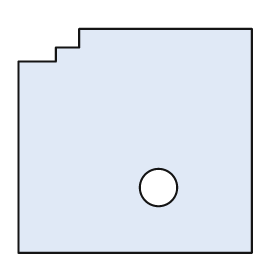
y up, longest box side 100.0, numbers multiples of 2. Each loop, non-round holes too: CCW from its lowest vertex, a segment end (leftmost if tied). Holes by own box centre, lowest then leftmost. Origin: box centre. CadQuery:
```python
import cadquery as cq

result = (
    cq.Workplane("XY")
    .moveTo(-50.0, -48.0)
    .lineTo(50.0, -48.0)
    .lineTo(50.0, 48.0)
    .lineTo(-24.0, 48.0)
    .lineTo(-24.0, 40.0)
    .lineTo(-34.0, 40.0)
    .lineTo(-34.0, 34.0)
    .lineTo(-50.0, 34.0)
    .close()
    .moveTo(10.0, -20.0)
    .circle(8.0)
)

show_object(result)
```